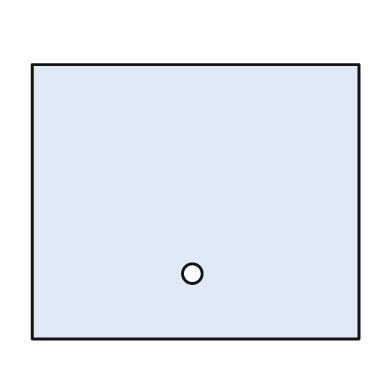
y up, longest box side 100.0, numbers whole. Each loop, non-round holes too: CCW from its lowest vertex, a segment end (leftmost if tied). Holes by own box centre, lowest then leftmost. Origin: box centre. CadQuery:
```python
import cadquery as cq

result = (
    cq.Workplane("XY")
    .moveTo(-50.0, -42.0)
    .lineTo(50.0, -42.0)
    .lineTo(50.0, 42.0)
    .lineTo(-50.0, 42.0)
    .close()
    .moveTo(-1.0, -22.0)
    .circle(3.0)
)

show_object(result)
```